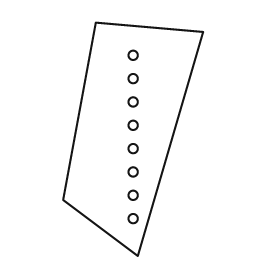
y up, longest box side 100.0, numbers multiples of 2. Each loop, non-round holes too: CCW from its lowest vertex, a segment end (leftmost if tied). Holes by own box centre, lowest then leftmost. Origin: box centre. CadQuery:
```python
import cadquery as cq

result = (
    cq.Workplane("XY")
    .moveTo(2.0, -50.0)
    .lineTo(30.0, 46.0)
    .lineTo(-16.0, 50.0)
    .lineTo(-30.0, -26.0)
    .close()
    .moveTo(0.0, -34.0)
    .circle(2.0)
    .moveTo(0.0, -24.0)
    .circle(2.0)
    .moveTo(0.0, -14.0)
    .circle(2.0)
    .moveTo(0.0, -4.0)
    .circle(2.0)
    .moveTo(0.0, 6.0)
    .circle(2.0)
    .moveTo(0.0, 16.0)
    .circle(2.0)
    .moveTo(0.0, 26.0)
    .circle(2.0)
    .moveTo(0.0, 36.0)
    .circle(2.0)
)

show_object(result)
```